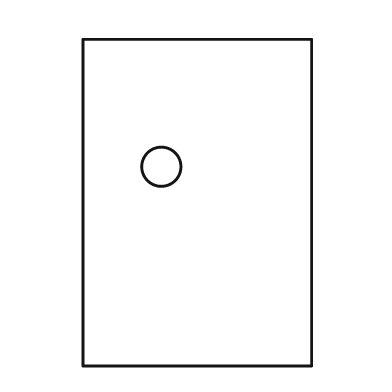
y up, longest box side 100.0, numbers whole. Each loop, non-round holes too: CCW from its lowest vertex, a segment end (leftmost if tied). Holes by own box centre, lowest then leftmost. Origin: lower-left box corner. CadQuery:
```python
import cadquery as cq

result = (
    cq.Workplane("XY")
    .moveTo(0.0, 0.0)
    .lineTo(70.0, 0.0)
    .lineTo(70.0, 100.0)
    .lineTo(0.0, 100.0)
    .close()
    .moveTo(24.0, 61.0)
    .circle(6.0)
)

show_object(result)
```